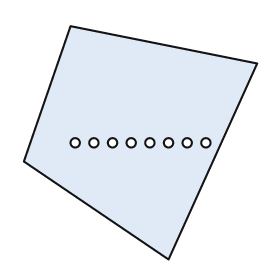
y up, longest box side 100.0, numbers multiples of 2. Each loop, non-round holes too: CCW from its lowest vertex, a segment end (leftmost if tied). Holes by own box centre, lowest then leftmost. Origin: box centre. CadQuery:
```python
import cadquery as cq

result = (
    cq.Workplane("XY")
    .moveTo(12.0, -50.0)
    .lineTo(50.0, 34.0)
    .lineTo(-30.0, 50.0)
    .lineTo(-50.0, -8.0)
    .close()
    .moveTo(-28.0, 0.0)
    .circle(2.0)
    .moveTo(-20.0, 0.0)
    .circle(2.0)
    .moveTo(-12.0, 0.0)
    .circle(2.0)
    .moveTo(-4.0, 0.0)
    .circle(2.0)
    .moveTo(4.0, 0.0)
    .circle(2.0)
    .moveTo(12.0, 0.0)
    .circle(2.0)
    .moveTo(20.0, 0.0)
    .circle(2.0)
    .moveTo(28.0, 0.0)
    .circle(2.0)
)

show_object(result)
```